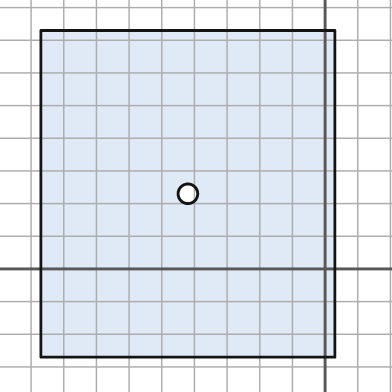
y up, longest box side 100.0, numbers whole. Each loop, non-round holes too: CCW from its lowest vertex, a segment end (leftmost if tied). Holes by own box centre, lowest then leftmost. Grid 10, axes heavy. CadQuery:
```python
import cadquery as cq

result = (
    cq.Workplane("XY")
    .moveTo(-87.0, -27.0)
    .lineTo(3.0, -27.0)
    .lineTo(3.0, 73.0)
    .lineTo(-87.0, 73.0)
    .close()
    .moveTo(-42.0, 23.0)
    .circle(3.0)
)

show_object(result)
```